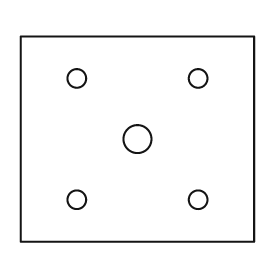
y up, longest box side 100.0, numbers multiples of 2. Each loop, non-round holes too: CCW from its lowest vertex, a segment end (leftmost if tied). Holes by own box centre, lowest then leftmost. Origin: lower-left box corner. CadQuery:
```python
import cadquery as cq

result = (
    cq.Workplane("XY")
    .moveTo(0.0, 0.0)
    .lineTo(100.0, 0.0)
    .lineTo(100.0, 88.0)
    .lineTo(0.0, 88.0)
    .close()
    .moveTo(24.0, 18.0)
    .circle(4.0)
    .moveTo(76.0, 18.0)
    .circle(4.0)
    .moveTo(50.0, 44.0)
    .circle(6.0)
    .moveTo(24.0, 70.0)
    .circle(4.0)
    .moveTo(76.0, 70.0)
    .circle(4.0)
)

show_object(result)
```